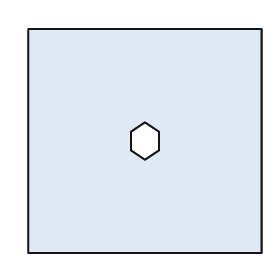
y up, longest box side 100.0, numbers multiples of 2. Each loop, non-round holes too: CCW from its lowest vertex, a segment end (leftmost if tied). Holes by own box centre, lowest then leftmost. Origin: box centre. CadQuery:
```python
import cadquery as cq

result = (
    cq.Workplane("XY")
    .moveTo(-50.0, -48.0)
    .lineTo(50.0, -48.0)
    .lineTo(50.0, 48.0)
    .lineTo(-50.0, 48.0)
    .close()
    .moveTo(0.0, -8.0)
    .lineTo(6.0, -4.0)
    .lineTo(6.0, 4.0)
    .lineTo(0.0, 8.0)
    .lineTo(-6.0, 4.0)
    .lineTo(-6.0, -4.0)
    .close()
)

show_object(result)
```